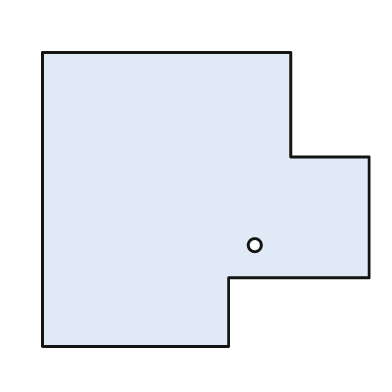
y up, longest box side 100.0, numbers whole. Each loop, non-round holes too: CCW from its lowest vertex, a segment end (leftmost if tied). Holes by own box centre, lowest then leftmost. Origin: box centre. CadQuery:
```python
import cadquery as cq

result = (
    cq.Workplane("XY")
    .moveTo(-50.0, -45.0)
    .lineTo(7.0, -45.0)
    .lineTo(7.0, -24.0)
    .lineTo(50.0, -24.0)
    .lineTo(50.0, 13.0)
    .lineTo(26.0, 13.0)
    .lineTo(26.0, 45.0)
    .lineTo(-50.0, 45.0)
    .close()
    .moveTo(15.0, -14.0)
    .circle(2.0)
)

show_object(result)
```